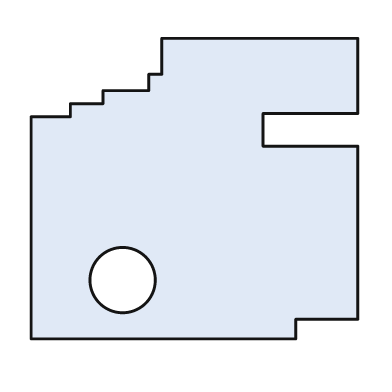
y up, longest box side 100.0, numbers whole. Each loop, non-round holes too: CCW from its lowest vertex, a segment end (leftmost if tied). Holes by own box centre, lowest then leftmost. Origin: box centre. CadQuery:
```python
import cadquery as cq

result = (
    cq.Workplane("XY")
    .moveTo(-50.0, -46.0)
    .lineTo(31.0, -46.0)
    .lineTo(31.0, -40.0)
    .lineTo(50.0, -40.0)
    .lineTo(50.0, 13.0)
    .lineTo(21.0, 13.0)
    .lineTo(21.0, 23.0)
    .lineTo(50.0, 23.0)
    .lineTo(50.0, 46.0)
    .lineTo(-10.0, 46.0)
    .lineTo(-10.0, 35.0)
    .lineTo(-14.0, 35.0)
    .lineTo(-14.0, 30.0)
    .lineTo(-28.0, 30.0)
    .lineTo(-28.0, 26.0)
    .lineTo(-38.0, 26.0)
    .lineTo(-38.0, 22.0)
    .lineTo(-50.0, 22.0)
    .close()
    .moveTo(-22.0, -28.0)
    .circle(10.0)
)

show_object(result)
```